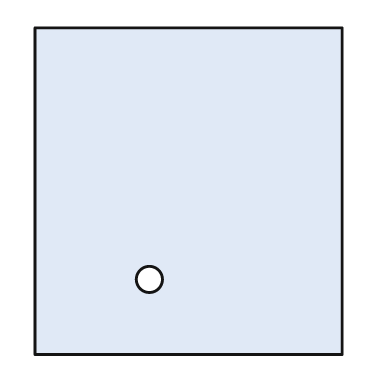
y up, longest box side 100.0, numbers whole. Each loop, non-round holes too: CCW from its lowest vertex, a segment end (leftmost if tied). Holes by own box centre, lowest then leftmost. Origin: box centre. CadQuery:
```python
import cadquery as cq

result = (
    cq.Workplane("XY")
    .moveTo(-47.0, -50.0)
    .lineTo(47.0, -50.0)
    .lineTo(47.0, 50.0)
    .lineTo(-47.0, 50.0)
    .close()
    .moveTo(-12.0, -27.0)
    .circle(4.0)
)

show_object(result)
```